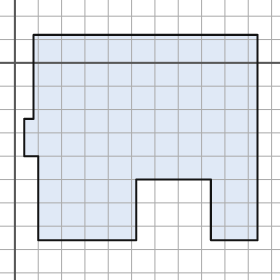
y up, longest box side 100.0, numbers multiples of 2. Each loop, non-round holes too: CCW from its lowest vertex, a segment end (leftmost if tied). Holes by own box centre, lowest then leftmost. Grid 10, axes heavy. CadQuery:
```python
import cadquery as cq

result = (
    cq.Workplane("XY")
    .moveTo(10.0, -76.0)
    .lineTo(52.0, -76.0)
    .lineTo(52.0, -50.0)
    .lineTo(84.0, -50.0)
    .lineTo(84.0, -76.0)
    .lineTo(104.0, -76.0)
    .lineTo(104.0, 12.0)
    .lineTo(8.0, 12.0)
    .lineTo(8.0, -24.0)
    .lineTo(4.0, -24.0)
    .lineTo(4.0, -40.0)
    .lineTo(10.0, -40.0)
    .close()
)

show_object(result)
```